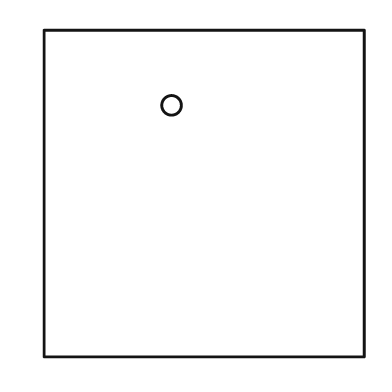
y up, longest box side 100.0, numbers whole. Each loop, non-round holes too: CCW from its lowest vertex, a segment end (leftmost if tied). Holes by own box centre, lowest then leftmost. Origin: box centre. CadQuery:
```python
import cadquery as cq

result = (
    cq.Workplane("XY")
    .moveTo(-49.0, -50.0)
    .lineTo(49.0, -50.0)
    .lineTo(49.0, 50.0)
    .lineTo(-49.0, 50.0)
    .close()
    .moveTo(-10.0, 27.0)
    .circle(3.0)
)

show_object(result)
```